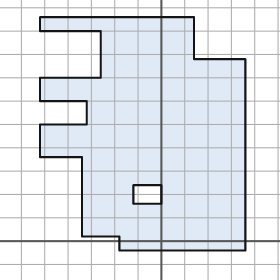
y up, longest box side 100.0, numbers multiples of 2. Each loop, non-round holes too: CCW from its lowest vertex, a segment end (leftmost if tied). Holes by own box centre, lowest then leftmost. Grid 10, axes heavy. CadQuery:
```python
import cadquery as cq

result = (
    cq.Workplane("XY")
    .moveTo(-18.0, -4.0)
    .lineTo(36.0, -4.0)
    .lineTo(36.0, 78.0)
    .lineTo(14.0, 78.0)
    .lineTo(14.0, 96.0)
    .lineTo(-52.0, 96.0)
    .lineTo(-52.0, 90.0)
    .lineTo(-26.0, 90.0)
    .lineTo(-26.0, 70.0)
    .lineTo(-52.0, 70.0)
    .lineTo(-52.0, 60.0)
    .lineTo(-32.0, 60.0)
    .lineTo(-32.0, 50.0)
    .lineTo(-52.0, 50.0)
    .lineTo(-52.0, 36.0)
    .lineTo(-34.0, 36.0)
    .lineTo(-34.0, 2.0)
    .lineTo(-18.0, 2.0)
    .close()
    .moveTo(-12.0, 16.0)
    .lineTo(0.0, 16.0)
    .lineTo(0.0, 24.0)
    .lineTo(-12.0, 24.0)
    .close()
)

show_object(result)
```